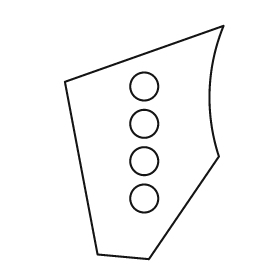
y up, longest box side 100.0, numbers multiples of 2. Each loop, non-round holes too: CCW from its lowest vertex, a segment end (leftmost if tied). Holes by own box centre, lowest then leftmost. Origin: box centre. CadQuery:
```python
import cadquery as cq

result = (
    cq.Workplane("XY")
    .moveTo(2.0, -50.0)
    .lineTo(32.0, -6.0)
    .threePointArc((28.0, 22.0), (34.0, 50.0))
    .lineTo(-34.0, 26.0)
    .lineTo(-20.0, -48.0)
    .close()
    .moveTo(0.0, -24.0)
    .circle(6.0)
    .moveTo(0.0, -8.0)
    .circle(6.0)
    .moveTo(0.0, 8.0)
    .circle(6.0)
    .moveTo(0.0, 24.0)
    .circle(6.0)
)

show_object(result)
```